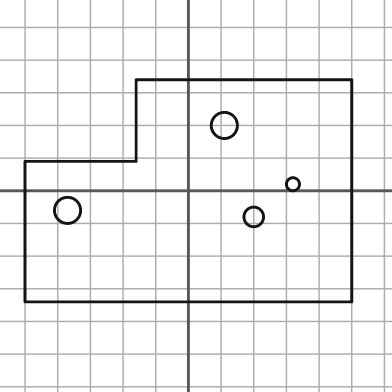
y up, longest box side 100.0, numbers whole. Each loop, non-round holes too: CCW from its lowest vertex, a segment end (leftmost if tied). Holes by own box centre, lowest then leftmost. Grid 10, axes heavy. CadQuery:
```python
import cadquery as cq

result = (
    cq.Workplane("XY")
    .moveTo(-50.0, -34.0)
    .lineTo(50.0, -34.0)
    .lineTo(50.0, 34.0)
    .lineTo(-16.0, 34.0)
    .lineTo(-16.0, 9.0)
    .lineTo(-50.0, 9.0)
    .close()
    .moveTo(20.0, -8.0)
    .circle(3.0)
    .moveTo(-37.0, -6.0)
    .circle(4.0)
    .moveTo(32.0, 2.0)
    .circle(2.0)
    .moveTo(11.0, 20.0)
    .circle(4.0)
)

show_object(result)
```